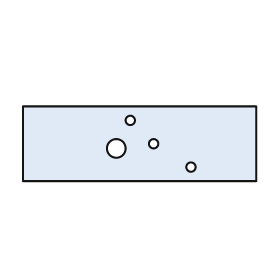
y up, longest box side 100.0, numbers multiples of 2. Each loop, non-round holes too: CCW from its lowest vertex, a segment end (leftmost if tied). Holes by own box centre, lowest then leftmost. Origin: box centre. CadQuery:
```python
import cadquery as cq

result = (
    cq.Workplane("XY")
    .moveTo(-50.0, -16.0)
    .lineTo(50.0, -16.0)
    .lineTo(50.0, 16.0)
    .lineTo(-50.0, 16.0)
    .close()
    .moveTo(22.0, -10.0)
    .circle(2.0)
    .moveTo(-10.0, -2.0)
    .circle(4.0)
    .moveTo(6.0, 0.0)
    .circle(2.0)
    .moveTo(-4.0, 10.0)
    .circle(2.0)
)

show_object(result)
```